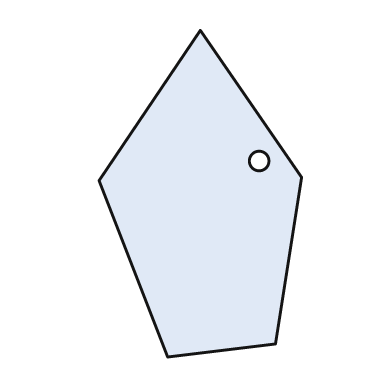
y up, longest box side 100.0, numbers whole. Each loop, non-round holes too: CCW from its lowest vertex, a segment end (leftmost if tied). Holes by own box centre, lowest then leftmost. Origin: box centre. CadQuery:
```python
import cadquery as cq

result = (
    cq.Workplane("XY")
    .moveTo(-10.0, -50.0)
    .lineTo(23.0, -46.0)
    .lineTo(31.0, 5.0)
    .lineTo(0.0, 50.0)
    .lineTo(-31.0, 4.0)
    .close()
    .moveTo(18.0, 10.0)
    .circle(3.0)
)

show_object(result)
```